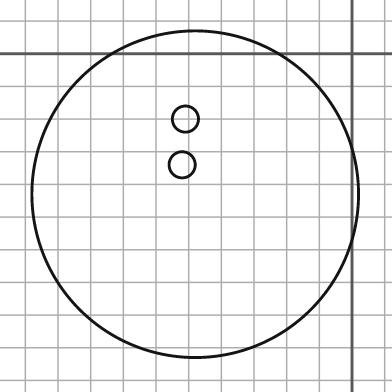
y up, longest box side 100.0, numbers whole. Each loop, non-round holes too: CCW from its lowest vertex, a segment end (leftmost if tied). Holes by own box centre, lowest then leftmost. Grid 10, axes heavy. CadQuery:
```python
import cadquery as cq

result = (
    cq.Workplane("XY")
    .moveTo(-48.0, -43.0)
    .circle(50.0)
    .moveTo(-52.0, -34.0)
    .circle(4.0)
    .moveTo(-51.0, -20.0)
    .circle(4.0)
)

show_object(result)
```